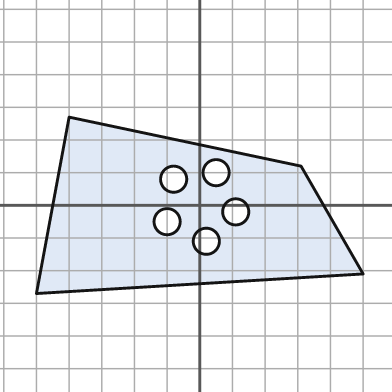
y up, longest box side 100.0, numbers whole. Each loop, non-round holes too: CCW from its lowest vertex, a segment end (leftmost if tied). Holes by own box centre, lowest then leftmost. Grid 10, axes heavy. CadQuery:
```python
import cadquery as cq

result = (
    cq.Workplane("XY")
    .moveTo(-50.0, -27.0)
    .lineTo(50.0, -21.0)
    .lineTo(31.0, 12.0)
    .lineTo(-40.0, 27.0)
    .close()
    .moveTo(2.0, -11.0)
    .circle(4.0)
    .moveTo(-10.0, -5.0)
    .circle(4.0)
    .moveTo(11.0, -2.0)
    .circle(4.0)
    .moveTo(-8.0, 8.0)
    .circle(4.0)
    .moveTo(5.0, 10.0)
    .circle(4.0)
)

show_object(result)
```